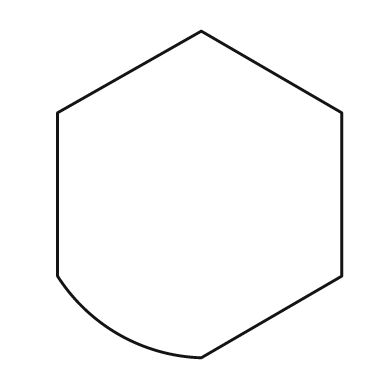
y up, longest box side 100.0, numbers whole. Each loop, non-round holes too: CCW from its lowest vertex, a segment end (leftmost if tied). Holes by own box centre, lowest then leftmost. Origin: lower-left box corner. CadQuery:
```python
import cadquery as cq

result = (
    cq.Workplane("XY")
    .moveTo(44.0, 0.0)
    .lineTo(87.0, 25.0)
    .lineTo(87.0, 75.0)
    .lineTo(44.0, 100.0)
    .lineTo(0.0, 75.0)
    .lineTo(0.0, 25.0)
    .threePointArc((19.0, 7.0), (44.0, 0.0))
    .close()
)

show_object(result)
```